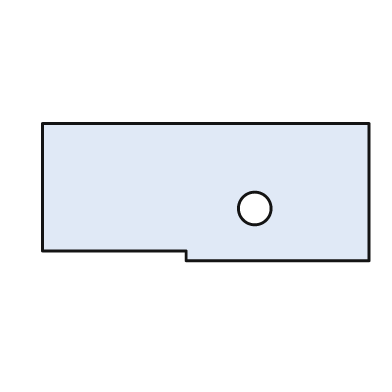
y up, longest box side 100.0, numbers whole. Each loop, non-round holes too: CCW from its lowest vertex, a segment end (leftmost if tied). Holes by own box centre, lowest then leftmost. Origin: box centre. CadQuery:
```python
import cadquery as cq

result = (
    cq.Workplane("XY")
    .moveTo(-6.0, -21.0)
    .lineTo(50.0, -21.0)
    .lineTo(50.0, 21.0)
    .lineTo(-50.0, 21.0)
    .lineTo(-50.0, -18.0)
    .lineTo(-6.0, -18.0)
    .close()
    .moveTo(15.0, -5.0)
    .circle(5.0)
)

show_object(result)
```